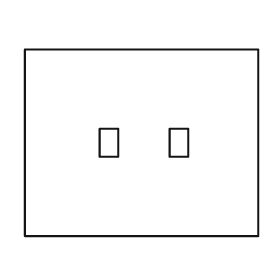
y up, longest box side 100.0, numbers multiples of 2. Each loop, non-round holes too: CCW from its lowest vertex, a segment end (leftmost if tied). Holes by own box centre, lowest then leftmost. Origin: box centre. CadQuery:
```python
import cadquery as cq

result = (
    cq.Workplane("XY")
    .moveTo(-50.0, -40.0)
    .lineTo(50.0, -40.0)
    .lineTo(50.0, 40.0)
    .lineTo(-50.0, 40.0)
    .close()
    .moveTo(-18.0, -6.0)
    .lineTo(-10.0, -6.0)
    .lineTo(-10.0, 6.0)
    .lineTo(-18.0, 6.0)
    .close()
    .moveTo(12.0, -6.0)
    .lineTo(20.0, -6.0)
    .lineTo(20.0, 6.0)
    .lineTo(12.0, 6.0)
    .close()
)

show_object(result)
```